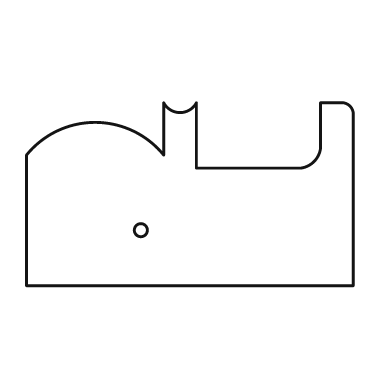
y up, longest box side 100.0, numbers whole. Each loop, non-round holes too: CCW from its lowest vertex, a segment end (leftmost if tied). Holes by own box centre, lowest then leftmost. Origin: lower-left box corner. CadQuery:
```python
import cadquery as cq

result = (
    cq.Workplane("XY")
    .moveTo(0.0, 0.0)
    .lineTo(100.0, 0.0)
    .lineTo(100.0, 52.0)
    .threePointArc((99.0, 55.0), (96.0, 56.0))
    .lineTo(90.0, 56.0)
    .lineTo(90.0, 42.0)
    .threePointArc((88.0, 38.0), (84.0, 36.0))
    .lineTo(52.0, 36.0)
    .lineTo(52.0, 56.0)
    .threePointArc((47.0, 53.0), (42.0, 56.0))
    .lineTo(42.0, 40.0)
    .threePointArc((21.0, 50.0), (0.0, 40.0))
    .close()
    .moveTo(35.0, 17.0)
    .circle(2.0)
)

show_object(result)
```